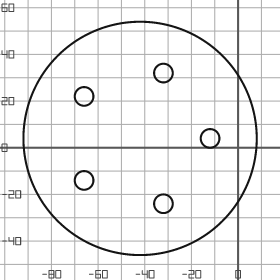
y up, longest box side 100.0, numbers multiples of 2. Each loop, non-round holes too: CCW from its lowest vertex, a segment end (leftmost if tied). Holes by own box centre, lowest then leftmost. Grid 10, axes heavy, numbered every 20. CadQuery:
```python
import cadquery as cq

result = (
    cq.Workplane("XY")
    .moveTo(-42.0, 4.0)
    .circle(50.0)
    .moveTo(-32.0, -24.0)
    .circle(4.0)
    .moveTo(-66.0, -14.0)
    .circle(4.0)
    .moveTo(-12.0, 4.0)
    .circle(4.0)
    .moveTo(-66.0, 22.0)
    .circle(4.0)
    .moveTo(-32.0, 32.0)
    .circle(4.0)
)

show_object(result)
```